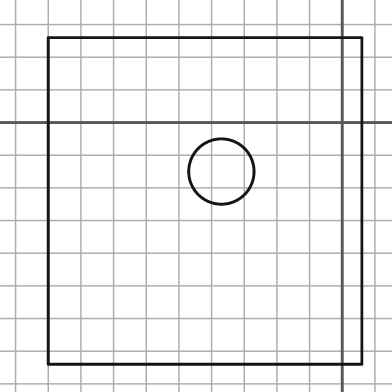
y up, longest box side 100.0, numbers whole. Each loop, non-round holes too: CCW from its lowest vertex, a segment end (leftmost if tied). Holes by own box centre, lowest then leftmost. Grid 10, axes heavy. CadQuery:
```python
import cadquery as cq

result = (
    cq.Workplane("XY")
    .moveTo(-90.0, -74.0)
    .lineTo(6.0, -74.0)
    .lineTo(6.0, 26.0)
    .lineTo(-90.0, 26.0)
    .close()
    .moveTo(-37.0, -15.0)
    .circle(10.0)
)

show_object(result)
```